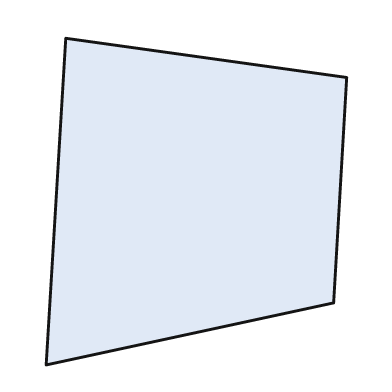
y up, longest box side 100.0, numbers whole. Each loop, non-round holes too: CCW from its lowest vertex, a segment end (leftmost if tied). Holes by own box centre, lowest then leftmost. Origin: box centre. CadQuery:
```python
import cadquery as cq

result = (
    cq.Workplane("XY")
    .moveTo(-46.0, -50.0)
    .lineTo(42.0, -31.0)
    .lineTo(46.0, 38.0)
    .lineTo(-40.0, 50.0)
    .close()
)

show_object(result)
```